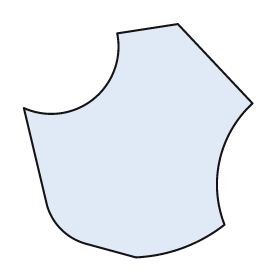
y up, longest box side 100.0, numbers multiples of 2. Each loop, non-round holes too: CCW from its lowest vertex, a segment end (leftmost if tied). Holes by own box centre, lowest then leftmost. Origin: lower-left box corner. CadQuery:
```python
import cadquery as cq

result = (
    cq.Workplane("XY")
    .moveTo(48.0, 0.0)
    .threePointArc((68.0, 4.0), (86.0, 14.0))
    .threePointArc((84.0, 42.0), (98.0, 66.0))
    .lineTo(66.0, 100.0)
    .lineTo(40.0, 96.0)
    .threePointArc((30.0, 68.0), (0.0, 64.0))
    .lineTo(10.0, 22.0)
    .threePointArc((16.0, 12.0), (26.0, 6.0))
    .close()
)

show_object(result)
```